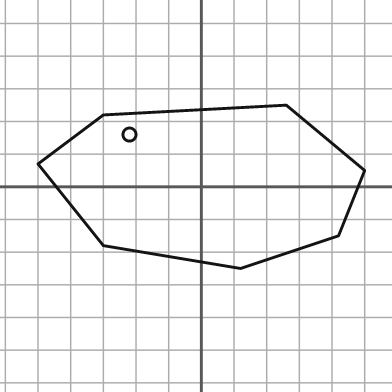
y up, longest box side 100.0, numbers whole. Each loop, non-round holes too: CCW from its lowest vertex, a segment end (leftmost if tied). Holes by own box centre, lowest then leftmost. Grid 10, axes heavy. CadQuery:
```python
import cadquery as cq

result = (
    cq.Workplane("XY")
    .moveTo(12.0, -25.0)
    .lineTo(42.0, -15.0)
    .lineTo(50.0, 5.0)
    .lineTo(26.0, 25.0)
    .lineTo(-30.0, 22.0)
    .lineTo(-50.0, 7.0)
    .lineTo(-30.0, -18.0)
    .close()
    .moveTo(-22.0, 16.0)
    .circle(2.0)
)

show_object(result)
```